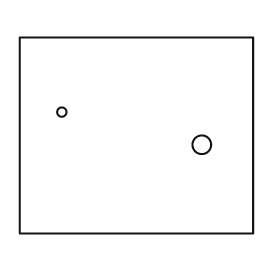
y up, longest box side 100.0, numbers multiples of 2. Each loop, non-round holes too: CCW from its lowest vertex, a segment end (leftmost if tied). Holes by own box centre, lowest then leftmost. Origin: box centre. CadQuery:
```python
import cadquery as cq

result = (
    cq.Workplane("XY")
    .moveTo(-50.0, -42.0)
    .lineTo(50.0, -42.0)
    .lineTo(50.0, 42.0)
    .lineTo(-50.0, 42.0)
    .close()
    .moveTo(28.0, -4.0)
    .circle(4.0)
    .moveTo(-32.0, 10.0)
    .circle(2.0)
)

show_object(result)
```